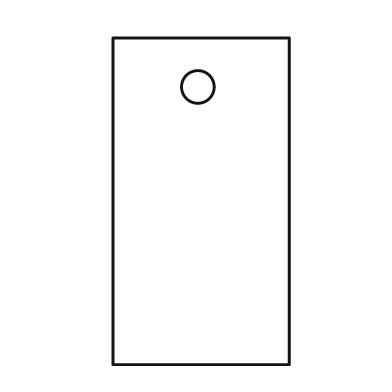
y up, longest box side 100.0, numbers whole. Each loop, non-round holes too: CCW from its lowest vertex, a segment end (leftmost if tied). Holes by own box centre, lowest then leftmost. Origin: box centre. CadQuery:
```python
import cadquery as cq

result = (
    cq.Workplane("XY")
    .moveTo(-27.0, -50.0)
    .lineTo(27.0, -50.0)
    .lineTo(27.0, 50.0)
    .lineTo(-27.0, 50.0)
    .close()
    .moveTo(-1.0, 35.0)
    .circle(5.0)
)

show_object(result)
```